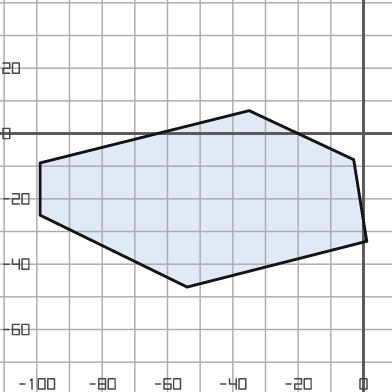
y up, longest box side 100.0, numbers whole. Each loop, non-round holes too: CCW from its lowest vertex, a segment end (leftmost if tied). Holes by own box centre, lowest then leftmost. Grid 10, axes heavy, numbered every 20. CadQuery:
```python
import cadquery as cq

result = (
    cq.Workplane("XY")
    .moveTo(-54.0, -47.0)
    .lineTo(1.0, -33.0)
    .lineTo(-3.0, -8.0)
    .lineTo(-35.0, 7.0)
    .lineTo(-99.0, -9.0)
    .lineTo(-99.0, -25.0)
    .close()
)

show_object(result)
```